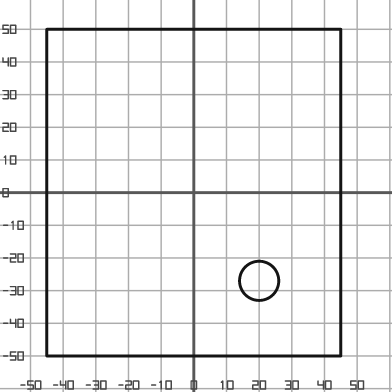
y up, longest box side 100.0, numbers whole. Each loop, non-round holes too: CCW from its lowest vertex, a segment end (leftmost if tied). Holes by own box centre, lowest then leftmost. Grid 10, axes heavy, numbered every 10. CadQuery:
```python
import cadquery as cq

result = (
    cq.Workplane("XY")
    .moveTo(-45.0, -50.0)
    .lineTo(45.0, -50.0)
    .lineTo(45.0, 50.0)
    .lineTo(-45.0, 50.0)
    .close()
    .moveTo(20.0, -27.0)
    .circle(6.0)
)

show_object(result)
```